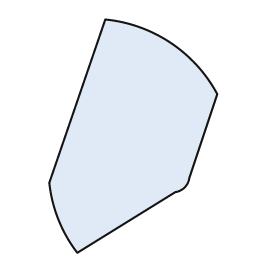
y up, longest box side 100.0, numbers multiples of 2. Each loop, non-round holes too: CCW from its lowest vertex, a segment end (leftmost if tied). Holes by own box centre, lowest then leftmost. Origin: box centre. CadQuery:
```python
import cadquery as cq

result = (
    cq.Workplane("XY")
    .moveTo(-24.0, -50.0)
    .lineTo(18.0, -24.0)
    .threePointArc((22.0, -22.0), (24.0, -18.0))
    .lineTo(36.0, 18.0)
    .threePointArc((16.0, 40.0), (-12.0, 50.0))
    .lineTo(-36.0, -20.0)
    .threePointArc((-32.0, -36.0), (-24.0, -50.0))
    .close()
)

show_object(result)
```